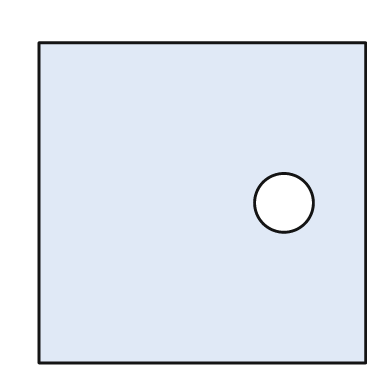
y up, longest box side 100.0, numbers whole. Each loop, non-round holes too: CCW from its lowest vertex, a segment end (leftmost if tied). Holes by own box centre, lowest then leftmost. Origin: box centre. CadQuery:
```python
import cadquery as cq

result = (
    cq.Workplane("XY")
    .moveTo(-50.0, -49.0)
    .lineTo(50.0, -49.0)
    .lineTo(50.0, 49.0)
    .lineTo(-50.0, 49.0)
    .close()
    .moveTo(25.0, 0.0)
    .circle(9.0)
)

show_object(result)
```